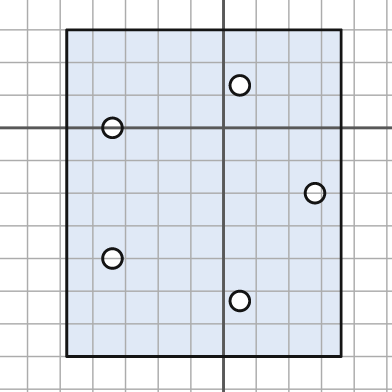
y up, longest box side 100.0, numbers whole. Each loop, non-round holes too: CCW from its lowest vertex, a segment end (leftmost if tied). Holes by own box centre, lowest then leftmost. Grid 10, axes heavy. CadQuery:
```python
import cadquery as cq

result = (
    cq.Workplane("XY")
    .moveTo(-48.0, -70.0)
    .lineTo(36.0, -70.0)
    .lineTo(36.0, 30.0)
    .lineTo(-48.0, 30.0)
    .close()
    .moveTo(5.0, -53.0)
    .circle(3.0)
    .moveTo(-34.0, -40.0)
    .circle(3.0)
    .moveTo(28.0, -20.0)
    .circle(3.0)
    .moveTo(-34.0, 0.0)
    .circle(3.0)
    .moveTo(5.0, 13.0)
    .circle(3.0)
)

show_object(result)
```